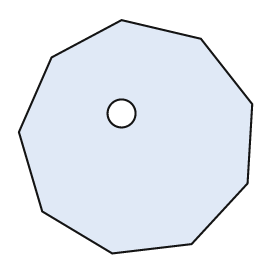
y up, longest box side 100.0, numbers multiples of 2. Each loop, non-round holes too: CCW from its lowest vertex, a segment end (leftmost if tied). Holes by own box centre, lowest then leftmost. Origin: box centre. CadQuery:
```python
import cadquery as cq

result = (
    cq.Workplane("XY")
    .moveTo(-10.0, -50.0)
    .lineTo(24.0, -46.0)
    .lineTo(48.0, -20.0)
    .lineTo(50.0, 14.0)
    .lineTo(28.0, 42.0)
    .lineTo(-6.0, 50.0)
    .lineTo(-36.0, 34.0)
    .lineTo(-50.0, 2.0)
    .lineTo(-40.0, -32.0)
    .close()
    .moveTo(-6.0, 10.0)
    .circle(6.0)
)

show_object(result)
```